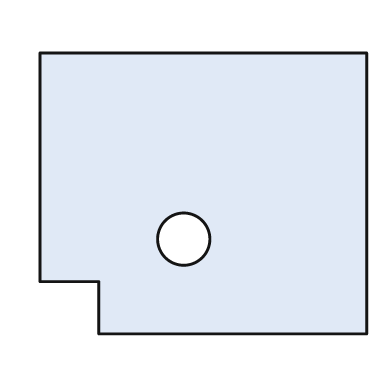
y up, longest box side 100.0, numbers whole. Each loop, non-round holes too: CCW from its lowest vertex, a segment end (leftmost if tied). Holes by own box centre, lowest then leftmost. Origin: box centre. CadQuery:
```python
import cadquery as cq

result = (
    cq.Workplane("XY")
    .moveTo(-32.0, -43.0)
    .lineTo(50.0, -43.0)
    .lineTo(50.0, 43.0)
    .lineTo(-50.0, 43.0)
    .lineTo(-50.0, -27.0)
    .lineTo(-32.0, -27.0)
    .close()
    .moveTo(-6.0, -14.0)
    .circle(8.0)
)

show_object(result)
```